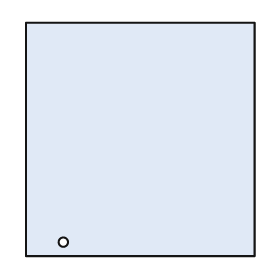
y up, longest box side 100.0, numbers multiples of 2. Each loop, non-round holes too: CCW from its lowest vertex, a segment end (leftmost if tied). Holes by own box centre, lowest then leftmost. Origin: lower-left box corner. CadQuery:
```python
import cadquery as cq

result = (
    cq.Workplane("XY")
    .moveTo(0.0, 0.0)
    .lineTo(98.0, 0.0)
    .lineTo(98.0, 100.0)
    .lineTo(0.0, 100.0)
    .close()
    .moveTo(16.0, 6.0)
    .circle(2.0)
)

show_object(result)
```